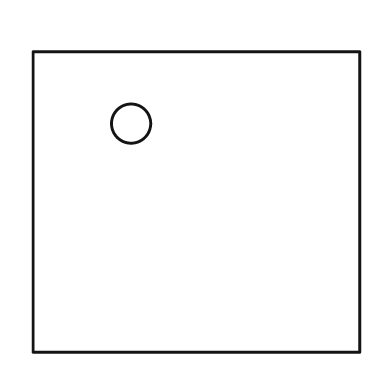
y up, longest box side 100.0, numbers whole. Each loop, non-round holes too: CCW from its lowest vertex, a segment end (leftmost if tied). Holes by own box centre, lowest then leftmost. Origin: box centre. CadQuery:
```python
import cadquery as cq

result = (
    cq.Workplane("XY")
    .moveTo(-50.0, -46.0)
    .lineTo(50.0, -46.0)
    .lineTo(50.0, 46.0)
    .lineTo(-50.0, 46.0)
    .close()
    .moveTo(-20.0, 24.0)
    .circle(6.0)
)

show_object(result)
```